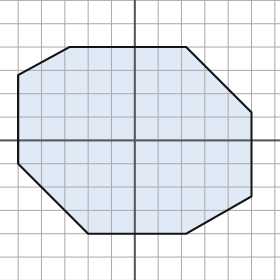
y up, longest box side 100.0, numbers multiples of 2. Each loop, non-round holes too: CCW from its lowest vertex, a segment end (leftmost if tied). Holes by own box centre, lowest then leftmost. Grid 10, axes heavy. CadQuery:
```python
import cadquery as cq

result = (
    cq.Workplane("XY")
    .moveTo(-20.0, -40.0)
    .lineTo(22.0, -40.0)
    .lineTo(50.0, -24.0)
    .lineTo(50.0, 12.0)
    .lineTo(22.0, 40.0)
    .lineTo(-28.0, 40.0)
    .lineTo(-50.0, 28.0)
    .lineTo(-50.0, -10.0)
    .close()
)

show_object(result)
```